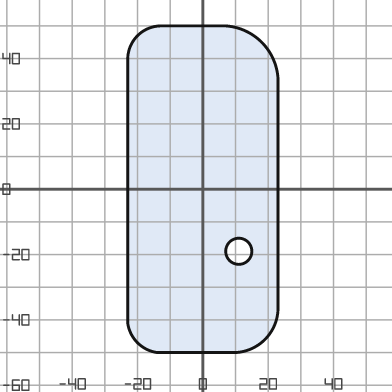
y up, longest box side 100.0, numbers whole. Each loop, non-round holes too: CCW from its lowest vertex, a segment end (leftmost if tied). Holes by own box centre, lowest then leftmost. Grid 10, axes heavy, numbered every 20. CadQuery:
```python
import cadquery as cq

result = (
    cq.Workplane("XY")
    .moveTo(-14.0, -50.0)
    .lineTo(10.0, -50.0)
    .threePointArc((19.0, -46.0), (23.0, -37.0))
    .lineTo(23.0, 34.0)
    .threePointArc((18.0, 45.0), (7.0, 50.0))
    .lineTo(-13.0, 50.0)
    .threePointArc((-20.0, 47.0), (-23.0, 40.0))
    .lineTo(-23.0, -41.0)
    .threePointArc((-20.0, -47.0), (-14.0, -50.0))
    .close()
    .moveTo(11.0, -19.0)
    .circle(4.0)
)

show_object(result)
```